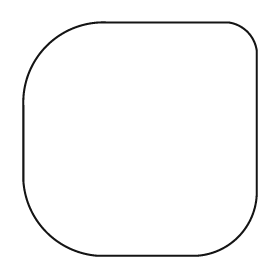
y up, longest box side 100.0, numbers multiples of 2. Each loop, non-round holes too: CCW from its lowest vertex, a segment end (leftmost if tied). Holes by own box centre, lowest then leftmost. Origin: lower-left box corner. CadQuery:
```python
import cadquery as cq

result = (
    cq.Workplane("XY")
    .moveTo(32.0, 0.0)
    .lineTo(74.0, 0.0)
    .threePointArc((92.0, 8.0), (100.0, 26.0))
    .lineTo(100.0, 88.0)
    .threePointArc((96.0, 96.0), (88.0, 100.0))
    .lineTo(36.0, 100.0)
    .threePointArc((10.0, 90.0), (0.0, 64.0))
    .lineTo(0.0, 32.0)
    .threePointArc((10.0, 10.0), (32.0, 0.0))
    .close()
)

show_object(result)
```